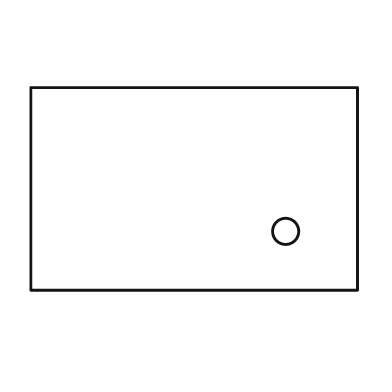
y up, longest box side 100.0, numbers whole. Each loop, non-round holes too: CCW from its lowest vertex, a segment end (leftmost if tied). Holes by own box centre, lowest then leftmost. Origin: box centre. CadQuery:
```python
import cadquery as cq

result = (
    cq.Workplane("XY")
    .moveTo(-50.0, -31.0)
    .lineTo(50.0, -31.0)
    .lineTo(50.0, 31.0)
    .lineTo(-50.0, 31.0)
    .close()
    .moveTo(28.0, -13.0)
    .circle(4.0)
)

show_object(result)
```